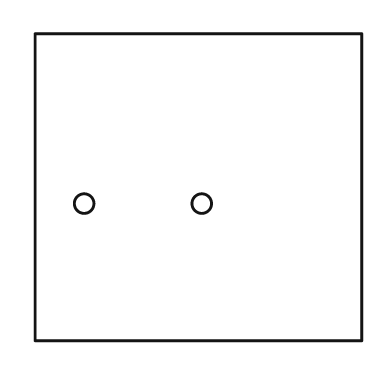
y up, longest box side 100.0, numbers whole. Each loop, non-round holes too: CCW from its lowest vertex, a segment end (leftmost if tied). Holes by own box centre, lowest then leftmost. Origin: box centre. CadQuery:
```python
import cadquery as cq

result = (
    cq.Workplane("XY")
    .moveTo(-50.0, -47.0)
    .lineTo(50.0, -47.0)
    .lineTo(50.0, 47.0)
    .lineTo(-50.0, 47.0)
    .close()
    .moveTo(-35.0, -5.0)
    .circle(3.0)
    .moveTo(1.0, -5.0)
    .circle(3.0)
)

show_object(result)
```